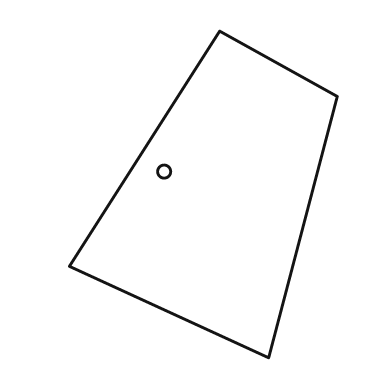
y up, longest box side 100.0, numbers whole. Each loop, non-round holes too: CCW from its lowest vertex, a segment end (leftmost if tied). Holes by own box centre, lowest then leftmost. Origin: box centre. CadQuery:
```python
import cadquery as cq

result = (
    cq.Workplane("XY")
    .moveTo(20.0, -50.0)
    .lineTo(41.0, 30.0)
    .lineTo(5.0, 50.0)
    .lineTo(-41.0, -22.0)
    .close()
    .moveTo(-12.0, 7.0)
    .circle(2.0)
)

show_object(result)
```